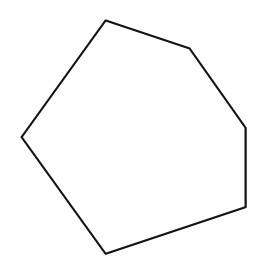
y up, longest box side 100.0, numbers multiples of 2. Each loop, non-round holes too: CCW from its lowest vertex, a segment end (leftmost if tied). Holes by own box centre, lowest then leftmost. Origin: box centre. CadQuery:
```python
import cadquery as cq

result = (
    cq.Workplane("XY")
    .moveTo(-12.0, -50.0)
    .lineTo(48.0, -30.0)
    .lineTo(48.0, 4.0)
    .lineTo(24.0, 38.0)
    .lineTo(-12.0, 50.0)
    .lineTo(-48.0, 0.0)
    .close()
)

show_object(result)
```